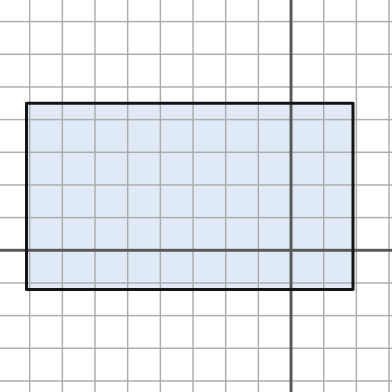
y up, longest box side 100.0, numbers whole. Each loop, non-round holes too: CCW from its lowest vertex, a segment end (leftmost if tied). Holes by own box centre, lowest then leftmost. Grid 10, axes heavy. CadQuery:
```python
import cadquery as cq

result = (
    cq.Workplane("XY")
    .moveTo(-81.0, -12.0)
    .lineTo(19.0, -12.0)
    .lineTo(19.0, 45.0)
    .lineTo(-81.0, 45.0)
    .close()
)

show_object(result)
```